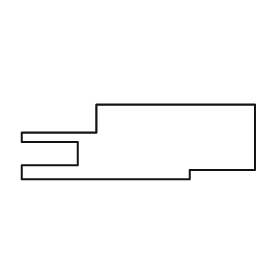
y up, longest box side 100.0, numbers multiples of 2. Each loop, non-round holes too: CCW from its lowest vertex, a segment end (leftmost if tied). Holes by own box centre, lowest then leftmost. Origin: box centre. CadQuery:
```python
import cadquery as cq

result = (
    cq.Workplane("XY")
    .moveTo(-50.0, -16.0)
    .lineTo(22.0, -16.0)
    .lineTo(22.0, -12.0)
    .lineTo(50.0, -12.0)
    .lineTo(50.0, 16.0)
    .lineTo(-18.0, 16.0)
    .lineTo(-18.0, 4.0)
    .lineTo(-50.0, 4.0)
    .lineTo(-50.0, 0.0)
    .lineTo(-26.0, 0.0)
    .lineTo(-26.0, -10.0)
    .lineTo(-50.0, -10.0)
    .close()
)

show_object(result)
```